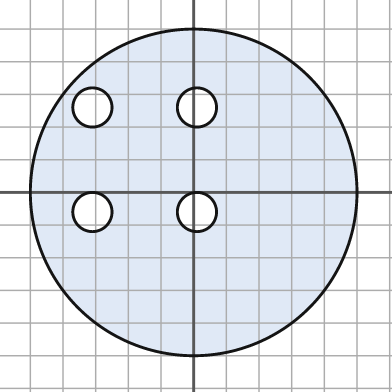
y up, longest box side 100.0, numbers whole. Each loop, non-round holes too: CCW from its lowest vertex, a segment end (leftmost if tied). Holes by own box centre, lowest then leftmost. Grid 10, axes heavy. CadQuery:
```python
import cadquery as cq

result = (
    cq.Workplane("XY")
    .moveTo(0.0, 0.0)
    .circle(50.0)
    .moveTo(-31.0, -6.0)
    .circle(6.0)
    .moveTo(1.0, -6.0)
    .circle(6.0)
    .moveTo(-31.0, 26.0)
    .circle(6.0)
    .moveTo(1.0, 26.0)
    .circle(6.0)
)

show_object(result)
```